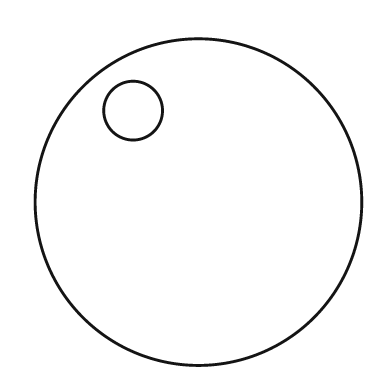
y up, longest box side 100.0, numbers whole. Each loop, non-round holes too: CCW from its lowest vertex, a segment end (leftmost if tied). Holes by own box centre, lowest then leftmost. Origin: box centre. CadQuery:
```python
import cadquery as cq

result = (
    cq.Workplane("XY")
    .moveTo(0.0, 0.0)
    .circle(50.0)
    .moveTo(-20.0, 28.0)
    .circle(9.0)
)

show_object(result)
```